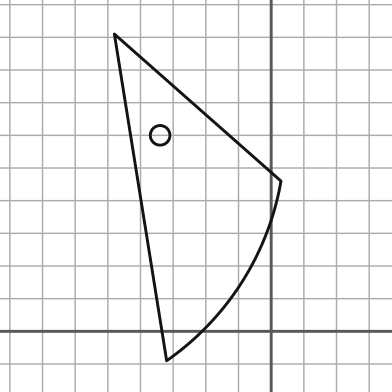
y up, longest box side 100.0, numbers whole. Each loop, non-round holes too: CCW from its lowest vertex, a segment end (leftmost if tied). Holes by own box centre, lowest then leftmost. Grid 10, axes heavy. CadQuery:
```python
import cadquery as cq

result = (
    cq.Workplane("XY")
    .moveTo(-32.0, -9.0)
    .threePointArc((-9.0, 15.0), (3.0, 46.0))
    .lineTo(-48.0, 91.0)
    .close()
    .moveTo(-34.0, 60.0)
    .circle(3.0)
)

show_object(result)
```